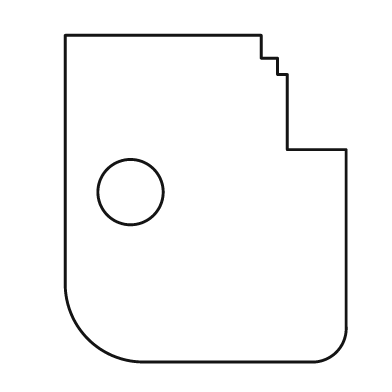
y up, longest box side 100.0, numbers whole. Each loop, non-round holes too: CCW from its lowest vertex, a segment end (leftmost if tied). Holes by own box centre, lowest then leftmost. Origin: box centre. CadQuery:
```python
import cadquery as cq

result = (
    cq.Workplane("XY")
    .moveTo(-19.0, -50.0)
    .lineTo(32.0, -50.0)
    .threePointArc((40.0, -47.0), (43.0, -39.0))
    .lineTo(43.0, 15.0)
    .lineTo(25.0, 15.0)
    .lineTo(25.0, 38.0)
    .lineTo(22.0, 38.0)
    .lineTo(22.0, 43.0)
    .lineTo(17.0, 43.0)
    .lineTo(17.0, 50.0)
    .lineTo(-43.0, 50.0)
    .lineTo(-43.0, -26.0)
    .threePointArc((-36.0, -43.0), (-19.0, -50.0))
    .close()
    .moveTo(-23.0, 2.0)
    .circle(10.0)
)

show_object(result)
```